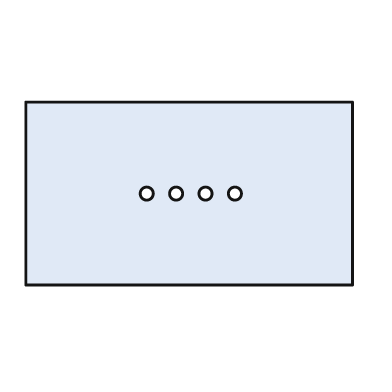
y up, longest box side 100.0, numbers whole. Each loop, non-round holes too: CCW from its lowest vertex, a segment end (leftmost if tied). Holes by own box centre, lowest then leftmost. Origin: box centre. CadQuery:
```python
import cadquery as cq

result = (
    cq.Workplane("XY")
    .moveTo(-50.0, -28.0)
    .lineTo(50.0, -28.0)
    .lineTo(50.0, 28.0)
    .lineTo(-50.0, 28.0)
    .close()
    .moveTo(-13.0, 0.0)
    .circle(2.0)
    .moveTo(-4.0, 0.0)
    .circle(2.0)
    .moveTo(5.0, 0.0)
    .circle(2.0)
    .moveTo(14.0, 0.0)
    .circle(2.0)
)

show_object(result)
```